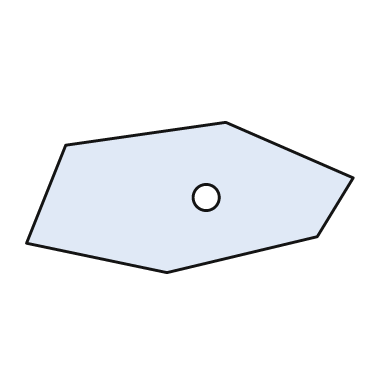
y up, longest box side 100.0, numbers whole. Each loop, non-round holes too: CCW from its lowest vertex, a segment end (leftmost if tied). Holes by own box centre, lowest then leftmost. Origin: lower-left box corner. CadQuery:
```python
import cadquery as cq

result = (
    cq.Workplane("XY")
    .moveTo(43.0, 0.0)
    .lineTo(89.0, 11.0)
    .lineTo(100.0, 29.0)
    .lineTo(61.0, 46.0)
    .lineTo(12.0, 39.0)
    .lineTo(0.0, 9.0)
    .close()
    .moveTo(55.0, 23.0)
    .circle(4.0)
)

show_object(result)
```